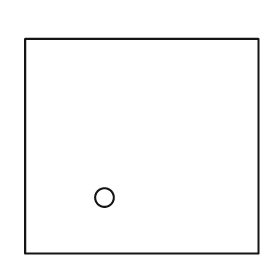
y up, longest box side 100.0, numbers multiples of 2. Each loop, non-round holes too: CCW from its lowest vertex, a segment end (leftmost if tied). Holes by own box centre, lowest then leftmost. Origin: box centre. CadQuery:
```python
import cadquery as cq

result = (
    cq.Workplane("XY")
    .moveTo(-50.0, -46.0)
    .lineTo(50.0, -46.0)
    .lineTo(50.0, 46.0)
    .lineTo(-50.0, 46.0)
    .close()
    .moveTo(-16.0, -22.0)
    .circle(4.0)
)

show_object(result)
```